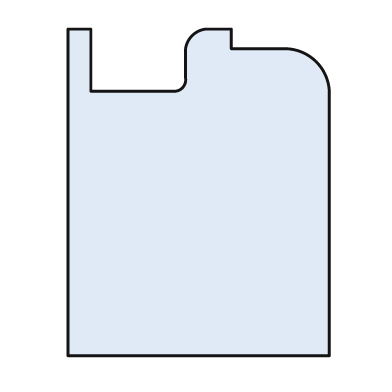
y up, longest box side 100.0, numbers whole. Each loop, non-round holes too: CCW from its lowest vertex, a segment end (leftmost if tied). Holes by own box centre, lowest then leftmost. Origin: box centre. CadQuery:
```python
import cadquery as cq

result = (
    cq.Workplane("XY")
    .moveTo(-40.0, -50.0)
    .lineTo(40.0, -50.0)
    .lineTo(40.0, 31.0)
    .threePointArc((36.0, 40.0), (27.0, 44.0))
    .lineTo(10.0, 44.0)
    .lineTo(10.0, 50.0)
    .lineTo(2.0, 50.0)
    .threePointArc((-2.0, 48.0), (-4.0, 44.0))
    .lineTo(-4.0, 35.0)
    .threePointArc((-5.0, 32.0), (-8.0, 31.0))
    .lineTo(-33.0, 31.0)
    .lineTo(-33.0, 50.0)
    .lineTo(-40.0, 50.0)
    .close()
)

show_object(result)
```